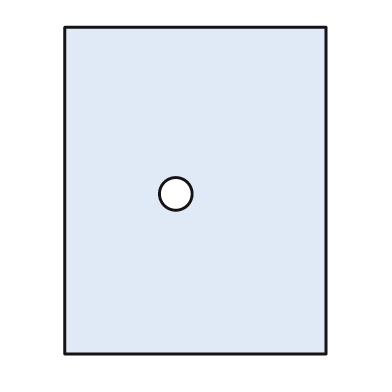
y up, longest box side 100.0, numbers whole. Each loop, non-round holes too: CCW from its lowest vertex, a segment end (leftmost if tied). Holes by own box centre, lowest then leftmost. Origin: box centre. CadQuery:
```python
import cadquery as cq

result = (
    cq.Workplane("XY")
    .moveTo(-40.0, -50.0)
    .lineTo(40.0, -50.0)
    .lineTo(40.0, 50.0)
    .lineTo(-40.0, 50.0)
    .close()
    .moveTo(-6.0, -1.0)
    .circle(5.0)
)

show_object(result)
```